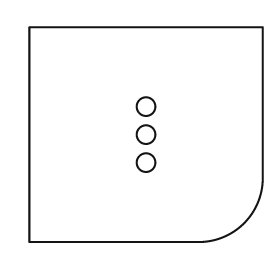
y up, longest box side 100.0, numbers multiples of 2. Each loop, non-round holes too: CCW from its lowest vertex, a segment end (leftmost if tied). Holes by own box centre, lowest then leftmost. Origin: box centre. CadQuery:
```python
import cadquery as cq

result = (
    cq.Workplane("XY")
    .moveTo(-50.0, -46.0)
    .lineTo(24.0, -46.0)
    .threePointArc((42.0, -38.0), (50.0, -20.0))
    .lineTo(50.0, 46.0)
    .lineTo(-50.0, 46.0)
    .close()
    .moveTo(0.0, -12.0)
    .circle(4.0)
    .moveTo(0.0, 0.0)
    .circle(4.0)
    .moveTo(0.0, 12.0)
    .circle(4.0)
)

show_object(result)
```